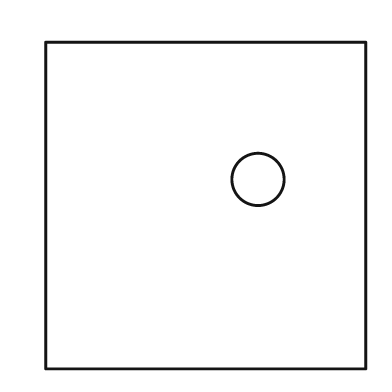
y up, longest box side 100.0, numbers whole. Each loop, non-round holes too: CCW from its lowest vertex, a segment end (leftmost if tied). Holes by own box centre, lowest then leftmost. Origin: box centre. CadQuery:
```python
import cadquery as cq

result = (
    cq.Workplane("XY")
    .moveTo(-49.0, -50.0)
    .lineTo(49.0, -50.0)
    .lineTo(49.0, 50.0)
    .lineTo(-49.0, 50.0)
    .close()
    .moveTo(16.0, 8.0)
    .circle(8.0)
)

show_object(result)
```